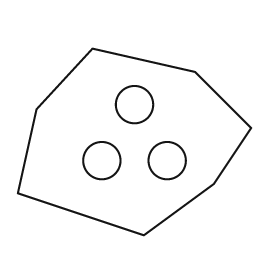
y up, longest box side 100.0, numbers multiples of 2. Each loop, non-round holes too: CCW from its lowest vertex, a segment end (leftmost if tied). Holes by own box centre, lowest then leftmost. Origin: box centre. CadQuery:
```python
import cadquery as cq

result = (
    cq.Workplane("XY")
    .moveTo(4.0, -40.0)
    .lineTo(34.0, -18.0)
    .lineTo(50.0, 6.0)
    .lineTo(26.0, 30.0)
    .lineTo(-18.0, 40.0)
    .lineTo(-42.0, 14.0)
    .lineTo(-50.0, -22.0)
    .close()
    .moveTo(-14.0, -8.0)
    .circle(8.0)
    .moveTo(14.0, -8.0)
    .circle(8.0)
    .moveTo(0.0, 16.0)
    .circle(8.0)
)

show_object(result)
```